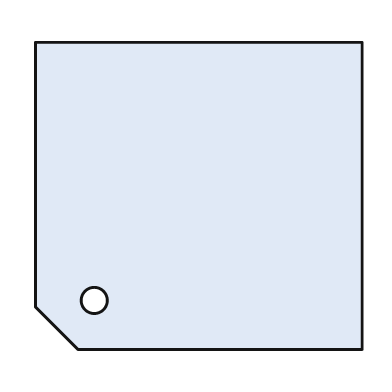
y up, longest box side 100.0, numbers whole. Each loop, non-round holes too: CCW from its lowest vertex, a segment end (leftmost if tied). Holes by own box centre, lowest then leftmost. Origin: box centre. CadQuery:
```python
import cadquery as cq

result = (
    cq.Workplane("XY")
    .moveTo(-37.0, -47.0)
    .lineTo(50.0, -47.0)
    .lineTo(50.0, 47.0)
    .lineTo(-50.0, 47.0)
    .lineTo(-50.0, -34.0)
    .close()
    .moveTo(-32.0, -32.0)
    .circle(4.0)
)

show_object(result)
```